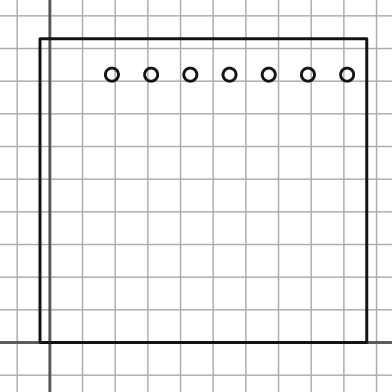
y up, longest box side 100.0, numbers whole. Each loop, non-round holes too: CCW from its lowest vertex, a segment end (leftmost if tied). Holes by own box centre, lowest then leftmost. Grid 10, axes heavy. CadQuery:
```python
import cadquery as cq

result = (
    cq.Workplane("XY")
    .moveTo(-3.0, 0.0)
    .lineTo(97.0, 0.0)
    .lineTo(97.0, 93.0)
    .lineTo(-3.0, 93.0)
    .close()
    .moveTo(19.0, 82.0)
    .circle(2.0)
    .moveTo(31.0, 82.0)
    .circle(2.0)
    .moveTo(43.0, 82.0)
    .circle(2.0)
    .moveTo(55.0, 82.0)
    .circle(2.0)
    .moveTo(67.0, 82.0)
    .circle(2.0)
    .moveTo(79.0, 82.0)
    .circle(2.0)
    .moveTo(91.0, 82.0)
    .circle(2.0)
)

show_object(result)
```